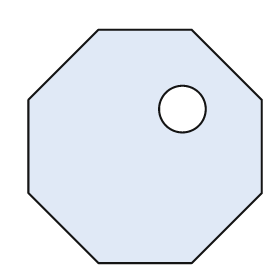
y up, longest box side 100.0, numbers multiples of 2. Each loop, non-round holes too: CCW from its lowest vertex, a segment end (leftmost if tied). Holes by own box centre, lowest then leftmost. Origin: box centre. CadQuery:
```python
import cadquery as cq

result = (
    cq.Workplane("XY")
    .moveTo(-20.0, -50.0)
    .lineTo(20.0, -50.0)
    .lineTo(50.0, -20.0)
    .lineTo(50.0, 20.0)
    .lineTo(20.0, 50.0)
    .lineTo(-20.0, 50.0)
    .lineTo(-50.0, 20.0)
    .lineTo(-50.0, -20.0)
    .close()
    .moveTo(16.0, 16.0)
    .circle(10.0)
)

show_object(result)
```